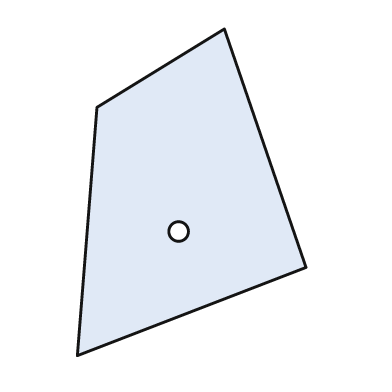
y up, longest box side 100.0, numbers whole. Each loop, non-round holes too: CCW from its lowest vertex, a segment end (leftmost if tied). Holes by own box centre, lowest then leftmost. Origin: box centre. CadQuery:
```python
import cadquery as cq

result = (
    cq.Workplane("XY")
    .moveTo(-35.0, -50.0)
    .lineTo(35.0, -23.0)
    .lineTo(10.0, 50.0)
    .lineTo(-29.0, 26.0)
    .close()
    .moveTo(-4.0, -12.0)
    .circle(3.0)
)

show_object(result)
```